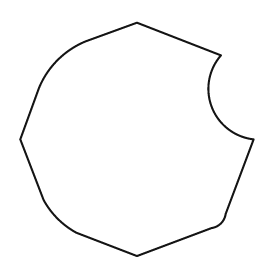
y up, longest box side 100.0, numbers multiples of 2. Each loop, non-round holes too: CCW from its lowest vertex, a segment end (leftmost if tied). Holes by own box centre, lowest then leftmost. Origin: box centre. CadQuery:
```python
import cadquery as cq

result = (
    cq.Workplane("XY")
    .moveTo(0.0, -50.0)
    .lineTo(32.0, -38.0)
    .threePointArc((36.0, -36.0), (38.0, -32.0))
    .lineTo(50.0, 0.0)
    .threePointArc((32.0, 14.0), (36.0, 36.0))
    .lineTo(0.0, 50.0)
    .lineTo(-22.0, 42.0)
    .threePointArc((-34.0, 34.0), (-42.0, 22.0))
    .lineTo(-50.0, 0.0)
    .lineTo(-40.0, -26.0)
    .threePointArc((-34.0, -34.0), (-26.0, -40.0))
    .close()
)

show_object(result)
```